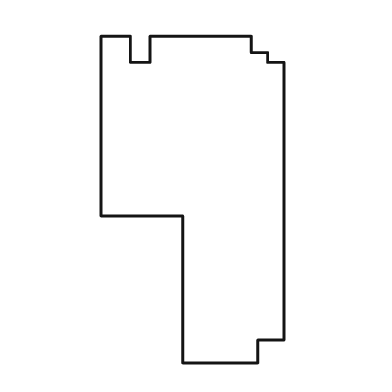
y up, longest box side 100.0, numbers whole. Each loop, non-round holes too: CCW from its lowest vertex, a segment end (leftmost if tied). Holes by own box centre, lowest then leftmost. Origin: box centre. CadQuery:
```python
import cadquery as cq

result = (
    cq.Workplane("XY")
    .moveTo(-3.0, -50.0)
    .lineTo(20.0, -50.0)
    .lineTo(20.0, -43.0)
    .lineTo(28.0, -43.0)
    .lineTo(28.0, 42.0)
    .lineTo(23.0, 42.0)
    .lineTo(23.0, 45.0)
    .lineTo(18.0, 45.0)
    .lineTo(18.0, 50.0)
    .lineTo(-13.0, 50.0)
    .lineTo(-13.0, 42.0)
    .lineTo(-19.0, 42.0)
    .lineTo(-19.0, 50.0)
    .lineTo(-28.0, 50.0)
    .lineTo(-28.0, -5.0)
    .lineTo(-3.0, -5.0)
    .close()
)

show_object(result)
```